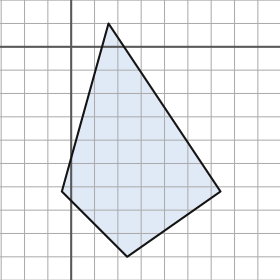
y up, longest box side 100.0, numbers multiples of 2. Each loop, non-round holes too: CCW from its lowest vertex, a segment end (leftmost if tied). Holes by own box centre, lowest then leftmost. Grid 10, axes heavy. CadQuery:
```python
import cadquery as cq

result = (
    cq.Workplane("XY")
    .moveTo(24.0, -90.0)
    .lineTo(64.0, -62.0)
    .lineTo(16.0, 10.0)
    .lineTo(-4.0, -62.0)
    .close()
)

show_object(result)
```